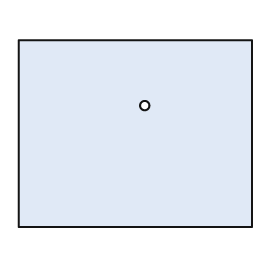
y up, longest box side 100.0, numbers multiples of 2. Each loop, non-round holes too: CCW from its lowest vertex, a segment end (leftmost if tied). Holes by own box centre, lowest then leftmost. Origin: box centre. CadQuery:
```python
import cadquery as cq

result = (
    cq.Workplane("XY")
    .moveTo(-50.0, -40.0)
    .lineTo(50.0, -40.0)
    .lineTo(50.0, 40.0)
    .lineTo(-50.0, 40.0)
    .close()
    .moveTo(4.0, 12.0)
    .circle(2.0)
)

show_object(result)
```